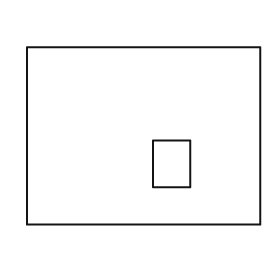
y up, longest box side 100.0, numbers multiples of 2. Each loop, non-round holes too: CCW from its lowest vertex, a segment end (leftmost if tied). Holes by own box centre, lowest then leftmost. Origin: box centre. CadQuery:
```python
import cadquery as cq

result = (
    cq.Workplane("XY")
    .moveTo(-50.0, -38.0)
    .lineTo(50.0, -38.0)
    .lineTo(50.0, 38.0)
    .lineTo(-50.0, 38.0)
    .close()
    .moveTo(4.0, -22.0)
    .lineTo(20.0, -22.0)
    .lineTo(20.0, -2.0)
    .lineTo(4.0, -2.0)
    .close()
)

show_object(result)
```